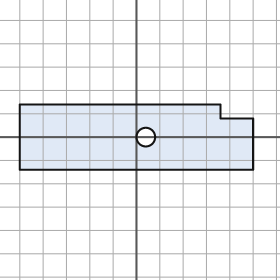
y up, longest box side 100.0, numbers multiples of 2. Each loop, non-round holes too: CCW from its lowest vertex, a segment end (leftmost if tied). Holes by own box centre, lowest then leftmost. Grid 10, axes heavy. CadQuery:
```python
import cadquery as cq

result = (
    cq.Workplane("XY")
    .moveTo(-50.0, -14.0)
    .lineTo(50.0, -14.0)
    .lineTo(50.0, 8.0)
    .lineTo(36.0, 8.0)
    .lineTo(36.0, 14.0)
    .lineTo(-50.0, 14.0)
    .close()
    .moveTo(4.0, 0.0)
    .circle(4.0)
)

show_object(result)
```